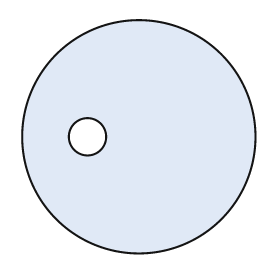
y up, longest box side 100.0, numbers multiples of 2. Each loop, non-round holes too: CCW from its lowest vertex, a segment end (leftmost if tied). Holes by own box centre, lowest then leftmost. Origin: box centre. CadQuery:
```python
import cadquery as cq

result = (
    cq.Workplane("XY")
    .moveTo(0.0, 0.0)
    .circle(50.0)
    .moveTo(-22.0, 0.0)
    .circle(8.0)
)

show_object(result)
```